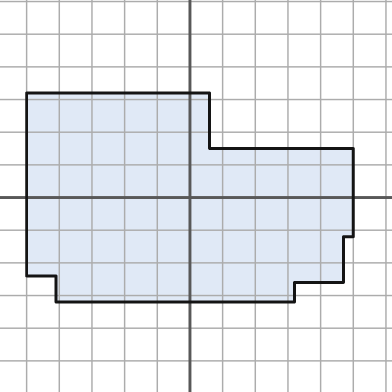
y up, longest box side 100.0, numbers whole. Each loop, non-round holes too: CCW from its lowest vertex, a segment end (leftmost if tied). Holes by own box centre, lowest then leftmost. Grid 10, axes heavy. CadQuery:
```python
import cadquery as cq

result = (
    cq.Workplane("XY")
    .moveTo(-41.0, -32.0)
    .lineTo(32.0, -32.0)
    .lineTo(32.0, -26.0)
    .lineTo(47.0, -26.0)
    .lineTo(47.0, -12.0)
    .lineTo(50.0, -12.0)
    .lineTo(50.0, 15.0)
    .lineTo(6.0, 15.0)
    .lineTo(6.0, 32.0)
    .lineTo(-50.0, 32.0)
    .lineTo(-50.0, -24.0)
    .lineTo(-41.0, -24.0)
    .close()
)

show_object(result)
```